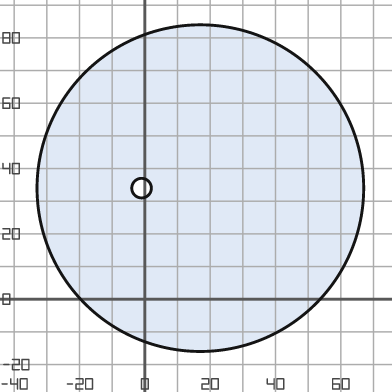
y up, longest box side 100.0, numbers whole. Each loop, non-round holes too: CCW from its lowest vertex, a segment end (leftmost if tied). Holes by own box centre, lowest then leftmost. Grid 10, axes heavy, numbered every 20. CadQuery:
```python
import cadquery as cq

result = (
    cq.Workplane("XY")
    .moveTo(17.0, 34.0)
    .circle(50.0)
    .moveTo(-1.0, 34.0)
    .circle(3.0)
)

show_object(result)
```